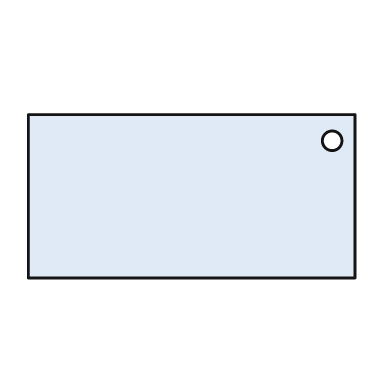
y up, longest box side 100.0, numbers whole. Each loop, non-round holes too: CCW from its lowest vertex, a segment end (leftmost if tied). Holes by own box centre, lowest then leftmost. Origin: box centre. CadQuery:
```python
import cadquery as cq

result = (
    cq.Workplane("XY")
    .moveTo(-50.0, -25.0)
    .lineTo(50.0, -25.0)
    .lineTo(50.0, 25.0)
    .lineTo(-50.0, 25.0)
    .close()
    .moveTo(43.0, 17.0)
    .circle(3.0)
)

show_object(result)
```